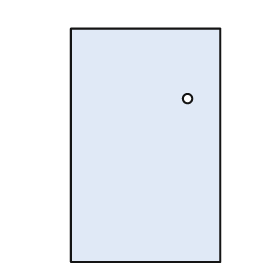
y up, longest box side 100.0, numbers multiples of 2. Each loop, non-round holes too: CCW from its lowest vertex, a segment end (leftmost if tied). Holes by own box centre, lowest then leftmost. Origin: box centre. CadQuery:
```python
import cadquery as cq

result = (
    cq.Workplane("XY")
    .moveTo(-32.0, -50.0)
    .lineTo(32.0, -50.0)
    .lineTo(32.0, 50.0)
    .lineTo(-32.0, 50.0)
    .close()
    .moveTo(18.0, 20.0)
    .circle(2.0)
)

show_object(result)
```